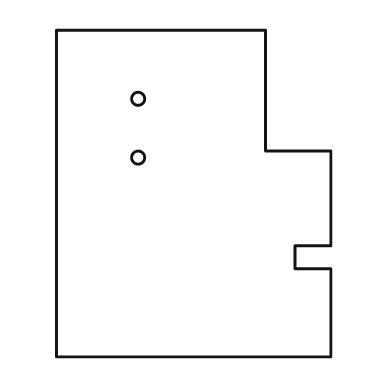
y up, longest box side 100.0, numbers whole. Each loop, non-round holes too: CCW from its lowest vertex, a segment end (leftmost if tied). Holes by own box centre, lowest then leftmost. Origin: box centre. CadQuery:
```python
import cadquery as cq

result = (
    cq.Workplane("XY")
    .moveTo(-42.0, -50.0)
    .lineTo(42.0, -50.0)
    .lineTo(42.0, -23.0)
    .lineTo(31.0, -23.0)
    .lineTo(31.0, -16.0)
    .lineTo(42.0, -16.0)
    .lineTo(42.0, 13.0)
    .lineTo(22.0, 13.0)
    .lineTo(22.0, 50.0)
    .lineTo(-42.0, 50.0)
    .close()
    .moveTo(-17.0, 11.0)
    .circle(2.0)
    .moveTo(-17.0, 29.0)
    .circle(2.0)
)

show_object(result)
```